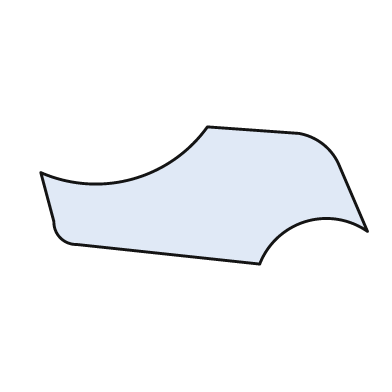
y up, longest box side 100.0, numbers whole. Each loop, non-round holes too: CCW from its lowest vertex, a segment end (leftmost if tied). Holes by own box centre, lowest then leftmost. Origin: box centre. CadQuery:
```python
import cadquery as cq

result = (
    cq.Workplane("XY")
    .moveTo(17.0, -21.0)
    .threePointArc((31.0, -8.0), (50.0, -11.0))
    .lineTo(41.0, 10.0)
    .threePointArc((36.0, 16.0), (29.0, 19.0))
    .lineTo(1.0, 21.0)
    .threePointArc((-22.0, 5.0), (-50.0, 7.0))
    .lineTo(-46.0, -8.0)
    .threePointArc((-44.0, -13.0), (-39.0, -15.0))
    .close()
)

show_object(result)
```